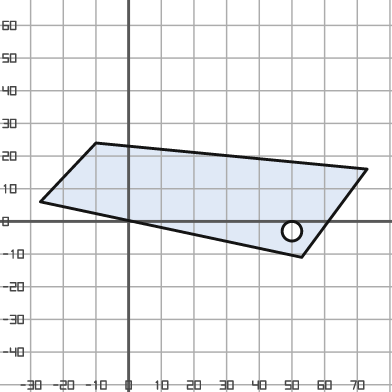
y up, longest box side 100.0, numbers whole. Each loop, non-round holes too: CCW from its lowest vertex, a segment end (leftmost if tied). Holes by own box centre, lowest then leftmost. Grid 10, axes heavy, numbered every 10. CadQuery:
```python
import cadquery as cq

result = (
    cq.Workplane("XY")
    .moveTo(53.0, -11.0)
    .lineTo(73.0, 16.0)
    .lineTo(-10.0, 24.0)
    .lineTo(-27.0, 6.0)
    .close()
    .moveTo(50.0, -3.0)
    .circle(3.0)
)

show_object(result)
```